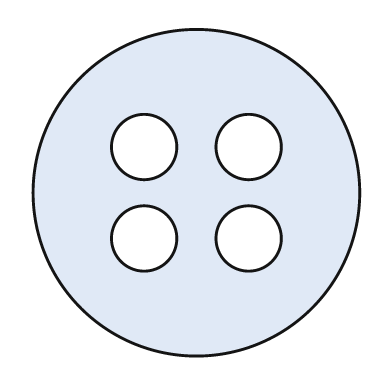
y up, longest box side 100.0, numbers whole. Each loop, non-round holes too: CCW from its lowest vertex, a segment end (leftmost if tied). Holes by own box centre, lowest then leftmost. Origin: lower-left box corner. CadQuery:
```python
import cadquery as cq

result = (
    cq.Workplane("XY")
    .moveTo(50.0, 50.0)
    .circle(50.0)
    .moveTo(34.0, 36.0)
    .circle(10.0)
    .moveTo(66.0, 36.0)
    .circle(10.0)
    .moveTo(34.0, 64.0)
    .circle(10.0)
    .moveTo(66.0, 64.0)
    .circle(10.0)
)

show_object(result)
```